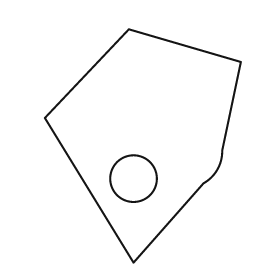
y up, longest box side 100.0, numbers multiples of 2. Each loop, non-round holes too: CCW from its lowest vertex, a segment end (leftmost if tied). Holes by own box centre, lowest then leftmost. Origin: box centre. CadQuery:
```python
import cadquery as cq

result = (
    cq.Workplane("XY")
    .moveTo(-4.0, -50.0)
    .lineTo(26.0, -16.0)
    .threePointArc((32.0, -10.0), (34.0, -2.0))
    .lineTo(42.0, 36.0)
    .lineTo(-6.0, 50.0)
    .lineTo(-42.0, 12.0)
    .close()
    .moveTo(-4.0, -14.0)
    .circle(10.0)
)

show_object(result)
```